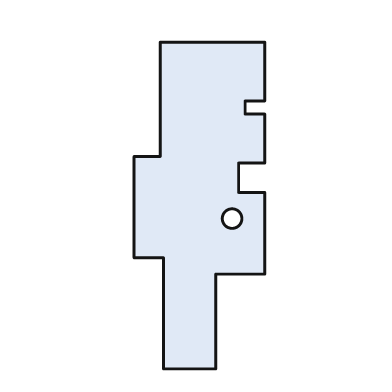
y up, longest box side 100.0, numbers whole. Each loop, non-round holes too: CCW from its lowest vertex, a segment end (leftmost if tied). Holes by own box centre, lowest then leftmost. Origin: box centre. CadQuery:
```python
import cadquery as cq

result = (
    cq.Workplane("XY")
    .moveTo(-11.0, -50.0)
    .lineTo(5.0, -50.0)
    .lineTo(5.0, -21.0)
    .lineTo(20.0, -21.0)
    .lineTo(20.0, 4.0)
    .lineTo(12.0, 4.0)
    .lineTo(12.0, 13.0)
    .lineTo(20.0, 13.0)
    .lineTo(20.0, 28.0)
    .lineTo(14.0, 28.0)
    .lineTo(14.0, 32.0)
    .lineTo(20.0, 32.0)
    .lineTo(20.0, 50.0)
    .lineTo(-12.0, 50.0)
    .lineTo(-12.0, 15.0)
    .lineTo(-20.0, 15.0)
    .lineTo(-20.0, -16.0)
    .lineTo(-11.0, -16.0)
    .close()
    .moveTo(10.0, -4.0)
    .circle(3.0)
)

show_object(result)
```